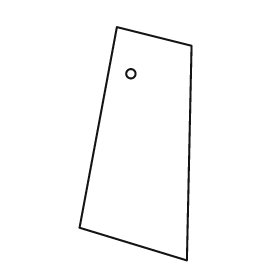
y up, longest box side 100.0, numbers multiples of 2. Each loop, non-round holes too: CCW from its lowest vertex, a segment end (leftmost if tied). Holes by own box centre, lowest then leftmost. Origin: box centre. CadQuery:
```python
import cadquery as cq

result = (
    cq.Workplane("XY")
    .moveTo(22.0, -50.0)
    .lineTo(24.0, 42.0)
    .lineTo(-8.0, 50.0)
    .lineTo(-24.0, -36.0)
    .close()
    .moveTo(-2.0, 30.0)
    .circle(2.0)
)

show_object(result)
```